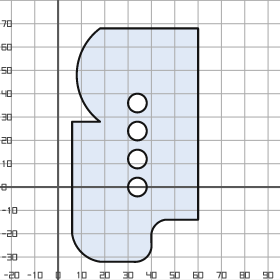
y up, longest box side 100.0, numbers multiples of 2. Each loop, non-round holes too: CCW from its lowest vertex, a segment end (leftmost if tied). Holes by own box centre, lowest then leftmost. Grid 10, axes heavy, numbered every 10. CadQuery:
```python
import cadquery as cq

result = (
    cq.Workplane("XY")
    .moveTo(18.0, -32.0)
    .lineTo(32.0, -32.0)
    .threePointArc((38.0, -30.0), (40.0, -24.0))
    .lineTo(40.0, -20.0)
    .threePointArc((42.0, -16.0), (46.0, -14.0))
    .lineTo(60.0, -14.0)
    .lineTo(60.0, 68.0)
    .lineTo(18.0, 68.0)
    .threePointArc((8.0, 48.0), (18.0, 28.0))
    .lineTo(6.0, 28.0)
    .lineTo(6.0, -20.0)
    .threePointArc((10.0, -28.0), (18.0, -32.0))
    .close()
    .moveTo(34.0, 0.0)
    .circle(4.0)
    .moveTo(34.0, 12.0)
    .circle(4.0)
    .moveTo(34.0, 24.0)
    .circle(4.0)
    .moveTo(34.0, 36.0)
    .circle(4.0)
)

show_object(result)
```